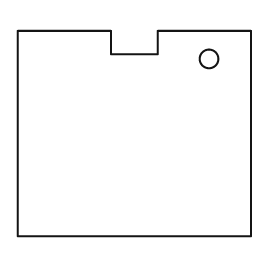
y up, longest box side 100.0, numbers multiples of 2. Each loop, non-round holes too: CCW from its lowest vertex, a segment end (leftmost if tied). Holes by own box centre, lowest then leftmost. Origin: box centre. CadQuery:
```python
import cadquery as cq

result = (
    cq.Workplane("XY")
    .moveTo(-50.0, -44.0)
    .lineTo(50.0, -44.0)
    .lineTo(50.0, 44.0)
    .lineTo(10.0, 44.0)
    .lineTo(10.0, 34.0)
    .lineTo(-10.0, 34.0)
    .lineTo(-10.0, 44.0)
    .lineTo(-50.0, 44.0)
    .close()
    .moveTo(32.0, 32.0)
    .circle(4.0)
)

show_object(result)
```